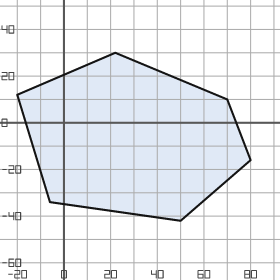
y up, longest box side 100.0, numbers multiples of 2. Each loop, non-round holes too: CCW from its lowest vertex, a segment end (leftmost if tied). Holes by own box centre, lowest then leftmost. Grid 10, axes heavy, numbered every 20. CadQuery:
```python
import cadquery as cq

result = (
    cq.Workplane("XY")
    .moveTo(50.0, -42.0)
    .lineTo(80.0, -16.0)
    .lineTo(70.0, 10.0)
    .lineTo(22.0, 30.0)
    .lineTo(-20.0, 12.0)
    .lineTo(-6.0, -34.0)
    .close()
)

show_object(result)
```